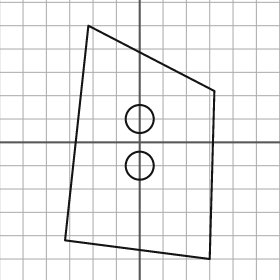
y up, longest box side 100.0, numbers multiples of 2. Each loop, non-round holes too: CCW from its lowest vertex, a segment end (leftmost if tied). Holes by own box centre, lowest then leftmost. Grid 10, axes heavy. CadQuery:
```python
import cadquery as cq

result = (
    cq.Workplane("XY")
    .moveTo(30.0, -50.0)
    .lineTo(32.0, 22.0)
    .lineTo(-22.0, 50.0)
    .lineTo(-32.0, -42.0)
    .close()
    .moveTo(0.0, -10.0)
    .circle(6.0)
    .moveTo(0.0, 10.0)
    .circle(6.0)
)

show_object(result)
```